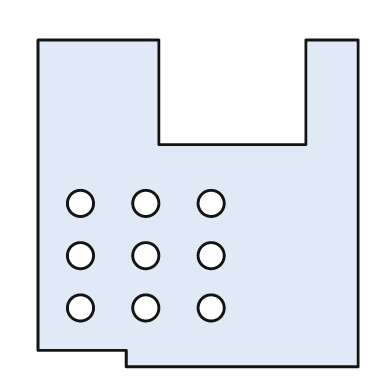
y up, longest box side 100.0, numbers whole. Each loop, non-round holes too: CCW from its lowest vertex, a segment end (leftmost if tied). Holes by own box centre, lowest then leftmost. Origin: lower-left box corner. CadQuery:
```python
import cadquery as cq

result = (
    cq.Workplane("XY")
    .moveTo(27.0, 0.0)
    .lineTo(98.0, 0.0)
    .lineTo(98.0, 100.0)
    .lineTo(82.0, 100.0)
    .lineTo(82.0, 68.0)
    .lineTo(37.0, 68.0)
    .lineTo(37.0, 100.0)
    .lineTo(0.0, 100.0)
    .lineTo(0.0, 5.0)
    .lineTo(27.0, 5.0)
    .close()
    .moveTo(13.0, 18.0)
    .circle(4.0)
    .moveTo(33.0, 18.0)
    .circle(4.0)
    .moveTo(53.0, 18.0)
    .circle(4.0)
    .moveTo(13.0, 34.0)
    .circle(4.0)
    .moveTo(33.0, 34.0)
    .circle(4.0)
    .moveTo(53.0, 34.0)
    .circle(4.0)
    .moveTo(13.0, 50.0)
    .circle(4.0)
    .moveTo(33.0, 50.0)
    .circle(4.0)
    .moveTo(53.0, 50.0)
    .circle(4.0)
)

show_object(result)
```